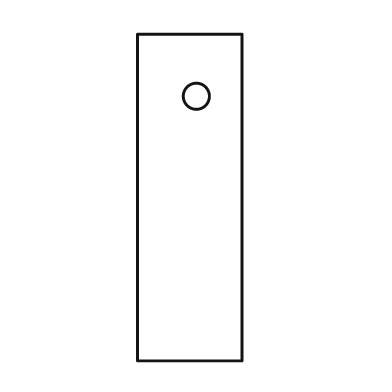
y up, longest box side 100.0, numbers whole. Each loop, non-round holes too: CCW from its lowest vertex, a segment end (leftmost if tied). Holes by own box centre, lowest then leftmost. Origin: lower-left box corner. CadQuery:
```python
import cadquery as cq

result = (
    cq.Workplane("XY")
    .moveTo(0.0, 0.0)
    .lineTo(32.0, 0.0)
    .lineTo(32.0, 100.0)
    .lineTo(0.0, 100.0)
    .close()
    .moveTo(18.0, 81.0)
    .circle(4.0)
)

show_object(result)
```